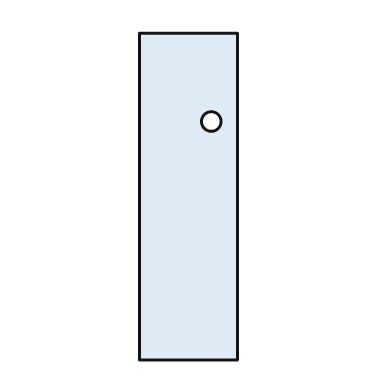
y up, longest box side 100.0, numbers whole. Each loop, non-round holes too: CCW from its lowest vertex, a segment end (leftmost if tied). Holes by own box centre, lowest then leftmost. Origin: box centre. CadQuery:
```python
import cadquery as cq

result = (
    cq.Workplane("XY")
    .moveTo(-15.0, -50.0)
    .lineTo(15.0, -50.0)
    .lineTo(15.0, 50.0)
    .lineTo(-15.0, 50.0)
    .close()
    .moveTo(7.0, 23.0)
    .circle(3.0)
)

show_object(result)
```